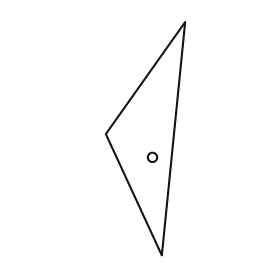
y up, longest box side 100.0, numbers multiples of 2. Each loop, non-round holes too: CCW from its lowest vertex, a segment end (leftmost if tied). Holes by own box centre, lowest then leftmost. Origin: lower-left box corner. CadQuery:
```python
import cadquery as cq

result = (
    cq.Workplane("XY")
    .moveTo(24.0, 0.0)
    .lineTo(34.0, 100.0)
    .lineTo(0.0, 52.0)
    .close()
    .moveTo(20.0, 42.0)
    .circle(2.0)
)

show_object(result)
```